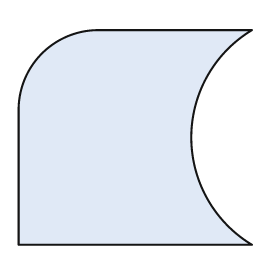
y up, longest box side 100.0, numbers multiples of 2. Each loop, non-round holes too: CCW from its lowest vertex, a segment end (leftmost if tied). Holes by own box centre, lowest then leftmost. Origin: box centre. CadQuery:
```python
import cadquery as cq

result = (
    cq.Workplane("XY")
    .moveTo(-50.0, -46.0)
    .lineTo(50.0, -46.0)
    .threePointArc((24.0, 0.0), (50.0, 46.0))
    .lineTo(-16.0, 46.0)
    .threePointArc((-40.0, 36.0), (-50.0, 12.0))
    .close()
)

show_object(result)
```